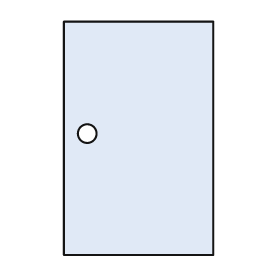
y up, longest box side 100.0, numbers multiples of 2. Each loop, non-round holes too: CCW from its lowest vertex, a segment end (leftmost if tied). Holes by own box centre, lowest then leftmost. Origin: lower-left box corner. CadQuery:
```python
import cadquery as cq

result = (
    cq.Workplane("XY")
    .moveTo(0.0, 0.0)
    .lineTo(64.0, 0.0)
    .lineTo(64.0, 100.0)
    .lineTo(0.0, 100.0)
    .close()
    .moveTo(10.0, 52.0)
    .circle(4.0)
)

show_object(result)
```